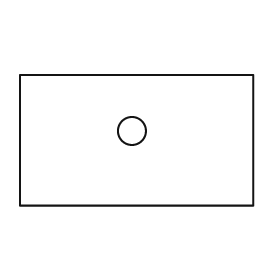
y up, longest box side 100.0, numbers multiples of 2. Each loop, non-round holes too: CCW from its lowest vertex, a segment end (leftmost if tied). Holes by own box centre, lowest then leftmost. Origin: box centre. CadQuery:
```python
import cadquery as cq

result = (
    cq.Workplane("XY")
    .moveTo(-50.0, -28.0)
    .lineTo(50.0, -28.0)
    .lineTo(50.0, 28.0)
    .lineTo(-50.0, 28.0)
    .close()
    .moveTo(-2.0, 4.0)
    .circle(6.0)
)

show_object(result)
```